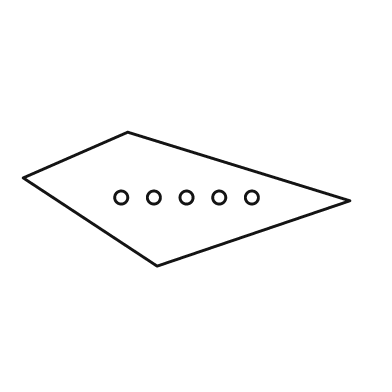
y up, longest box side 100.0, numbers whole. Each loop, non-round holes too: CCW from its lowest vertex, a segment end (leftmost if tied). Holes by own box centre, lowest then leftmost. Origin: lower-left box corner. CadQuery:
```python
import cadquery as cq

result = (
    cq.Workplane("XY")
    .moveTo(41.0, 0.0)
    .lineTo(100.0, 20.0)
    .lineTo(32.0, 41.0)
    .lineTo(0.0, 27.0)
    .close()
    .moveTo(30.0, 21.0)
    .circle(2.0)
    .moveTo(40.0, 21.0)
    .circle(2.0)
    .moveTo(50.0, 21.0)
    .circle(2.0)
    .moveTo(60.0, 21.0)
    .circle(2.0)
    .moveTo(70.0, 21.0)
    .circle(2.0)
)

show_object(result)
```